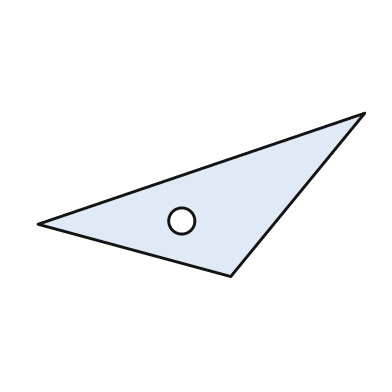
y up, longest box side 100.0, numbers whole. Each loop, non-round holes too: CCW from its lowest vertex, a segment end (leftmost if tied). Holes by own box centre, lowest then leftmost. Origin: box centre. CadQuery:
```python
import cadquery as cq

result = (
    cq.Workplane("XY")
    .moveTo(9.0, -25.0)
    .lineTo(50.0, 25.0)
    .lineTo(-50.0, -9.0)
    .close()
    .moveTo(-6.0, -8.0)
    .circle(4.0)
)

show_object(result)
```